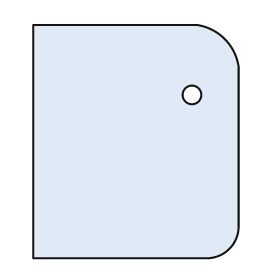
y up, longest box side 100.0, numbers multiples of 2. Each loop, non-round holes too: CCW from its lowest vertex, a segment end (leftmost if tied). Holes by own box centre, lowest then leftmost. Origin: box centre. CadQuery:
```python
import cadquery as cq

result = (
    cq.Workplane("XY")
    .moveTo(-44.0, -50.0)
    .lineTo(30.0, -50.0)
    .threePointArc((40.0, -46.0), (44.0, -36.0))
    .lineTo(44.0, 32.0)
    .threePointArc((38.0, 44.0), (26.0, 50.0))
    .lineTo(-44.0, 50.0)
    .close()
    .moveTo(24.0, 20.0)
    .circle(4.0)
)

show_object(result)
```